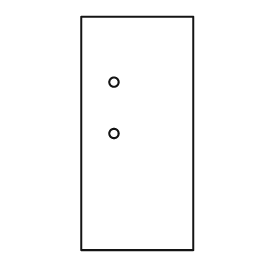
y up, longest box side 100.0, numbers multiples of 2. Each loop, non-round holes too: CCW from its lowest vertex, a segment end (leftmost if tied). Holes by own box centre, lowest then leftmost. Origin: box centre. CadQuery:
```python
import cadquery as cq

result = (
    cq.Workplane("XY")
    .moveTo(-24.0, -50.0)
    .lineTo(24.0, -50.0)
    .lineTo(24.0, 50.0)
    .lineTo(-24.0, 50.0)
    .close()
    .moveTo(-10.0, 0.0)
    .circle(2.0)
    .moveTo(-10.0, 22.0)
    .circle(2.0)
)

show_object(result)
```